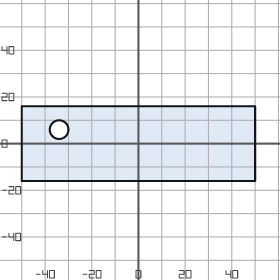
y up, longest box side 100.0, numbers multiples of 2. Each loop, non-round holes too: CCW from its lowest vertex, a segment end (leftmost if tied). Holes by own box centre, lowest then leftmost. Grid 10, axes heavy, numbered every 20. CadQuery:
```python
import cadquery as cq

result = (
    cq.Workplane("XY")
    .moveTo(-50.0, -16.0)
    .lineTo(50.0, -16.0)
    .lineTo(50.0, 16.0)
    .lineTo(-50.0, 16.0)
    .close()
    .moveTo(-34.0, 6.0)
    .circle(4.0)
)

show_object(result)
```